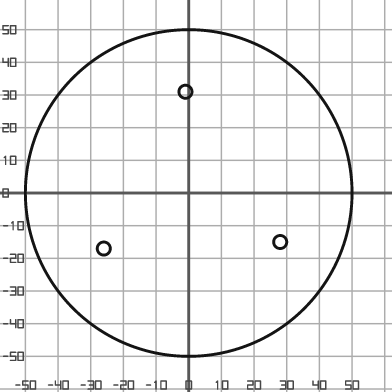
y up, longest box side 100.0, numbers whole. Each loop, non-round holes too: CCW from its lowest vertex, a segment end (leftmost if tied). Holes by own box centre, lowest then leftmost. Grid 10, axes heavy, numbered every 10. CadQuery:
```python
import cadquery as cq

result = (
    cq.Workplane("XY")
    .moveTo(0.0, 0.0)
    .circle(50.0)
    .moveTo(-26.0, -17.0)
    .circle(2.0)
    .moveTo(28.0, -15.0)
    .circle(2.0)
    .moveTo(-1.0, 31.0)
    .circle(2.0)
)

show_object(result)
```